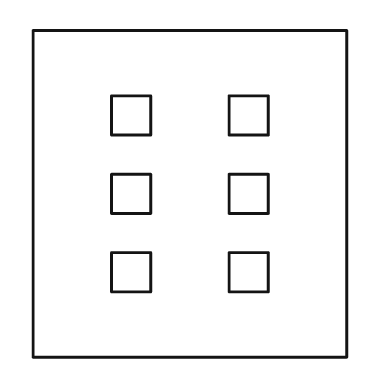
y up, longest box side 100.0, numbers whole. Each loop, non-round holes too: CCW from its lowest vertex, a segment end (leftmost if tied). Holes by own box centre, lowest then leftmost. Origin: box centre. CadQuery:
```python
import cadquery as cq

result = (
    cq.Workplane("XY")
    .moveTo(-48.0, -50.0)
    .lineTo(48.0, -50.0)
    .lineTo(48.0, 50.0)
    .lineTo(-48.0, 50.0)
    .close()
    .moveTo(-24.0, -30.0)
    .lineTo(-12.0, -30.0)
    .lineTo(-12.0, -18.0)
    .lineTo(-24.0, -18.0)
    .close()
    .moveTo(12.0, -30.0)
    .lineTo(24.0, -30.0)
    .lineTo(24.0, -18.0)
    .lineTo(12.0, -18.0)
    .close()
    .moveTo(-24.0, -6.0)
    .lineTo(-12.0, -6.0)
    .lineTo(-12.0, 6.0)
    .lineTo(-24.0, 6.0)
    .close()
    .moveTo(12.0, -6.0)
    .lineTo(24.0, -6.0)
    .lineTo(24.0, 6.0)
    .lineTo(12.0, 6.0)
    .close()
    .moveTo(-24.0, 18.0)
    .lineTo(-12.0, 18.0)
    .lineTo(-12.0, 30.0)
    .lineTo(-24.0, 30.0)
    .close()
    .moveTo(12.0, 18.0)
    .lineTo(24.0, 18.0)
    .lineTo(24.0, 30.0)
    .lineTo(12.0, 30.0)
    .close()
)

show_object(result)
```